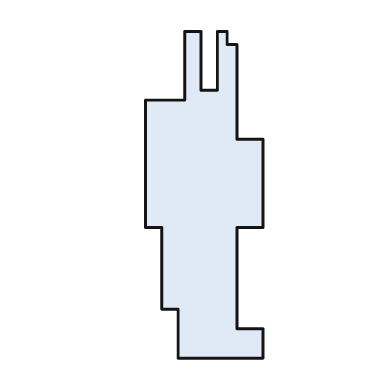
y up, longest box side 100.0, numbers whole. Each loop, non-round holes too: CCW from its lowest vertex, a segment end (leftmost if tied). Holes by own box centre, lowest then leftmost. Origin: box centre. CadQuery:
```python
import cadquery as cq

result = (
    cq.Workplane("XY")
    .moveTo(-8.0, -50.0)
    .lineTo(18.0, -50.0)
    .lineTo(18.0, -41.0)
    .lineTo(10.0, -41.0)
    .lineTo(10.0, -10.0)
    .lineTo(18.0, -10.0)
    .lineTo(18.0, 17.0)
    .lineTo(10.0, 17.0)
    .lineTo(10.0, 46.0)
    .lineTo(7.0, 46.0)
    .lineTo(7.0, 50.0)
    .lineTo(4.0, 50.0)
    .lineTo(4.0, 32.0)
    .lineTo(-1.0, 32.0)
    .lineTo(-1.0, 50.0)
    .lineTo(-6.0, 50.0)
    .lineTo(-6.0, 29.0)
    .lineTo(-18.0, 29.0)
    .lineTo(-18.0, -10.0)
    .lineTo(-13.0, -10.0)
    .lineTo(-13.0, -35.0)
    .lineTo(-8.0, -35.0)
    .close()
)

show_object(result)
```